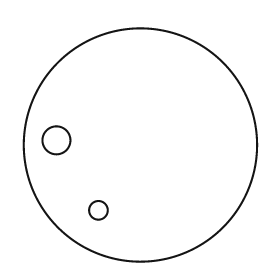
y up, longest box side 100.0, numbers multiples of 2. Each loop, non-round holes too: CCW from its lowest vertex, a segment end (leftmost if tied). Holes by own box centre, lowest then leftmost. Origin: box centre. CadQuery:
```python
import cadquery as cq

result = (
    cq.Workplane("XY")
    .moveTo(0.0, 0.0)
    .circle(50.0)
    .moveTo(-18.0, -28.0)
    .circle(4.0)
    .moveTo(-36.0, 2.0)
    .circle(6.0)
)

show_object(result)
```